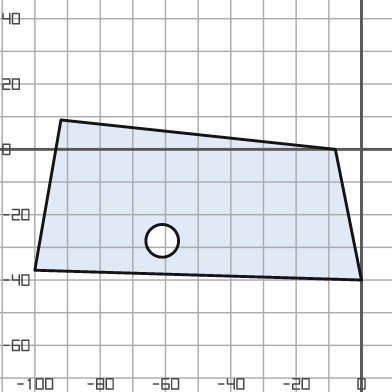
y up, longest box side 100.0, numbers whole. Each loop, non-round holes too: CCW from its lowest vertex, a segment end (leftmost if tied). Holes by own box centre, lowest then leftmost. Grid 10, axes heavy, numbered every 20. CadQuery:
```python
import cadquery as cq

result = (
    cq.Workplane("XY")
    .moveTo(0.0, -40.0)
    .lineTo(-8.0, 0.0)
    .lineTo(-92.0, 9.0)
    .lineTo(-100.0, -37.0)
    .close()
    .moveTo(-61.0, -28.0)
    .circle(5.0)
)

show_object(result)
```